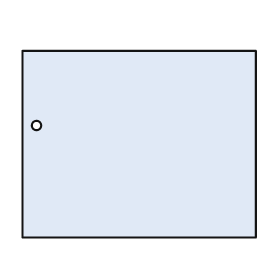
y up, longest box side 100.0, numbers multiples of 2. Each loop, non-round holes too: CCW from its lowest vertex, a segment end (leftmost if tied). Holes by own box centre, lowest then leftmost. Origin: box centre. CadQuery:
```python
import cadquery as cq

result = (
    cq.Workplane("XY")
    .moveTo(-50.0, -40.0)
    .lineTo(50.0, -40.0)
    .lineTo(50.0, 40.0)
    .lineTo(-50.0, 40.0)
    .close()
    .moveTo(-44.0, 8.0)
    .circle(2.0)
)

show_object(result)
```